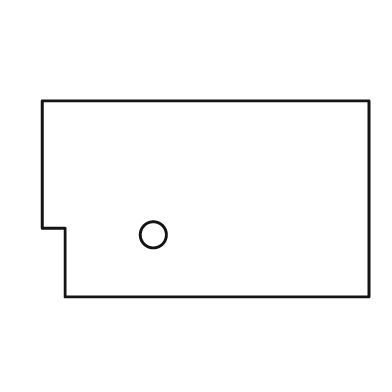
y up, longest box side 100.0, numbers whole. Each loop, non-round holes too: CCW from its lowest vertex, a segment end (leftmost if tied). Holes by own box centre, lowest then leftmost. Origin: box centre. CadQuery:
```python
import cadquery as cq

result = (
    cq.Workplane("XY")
    .moveTo(-43.0, -30.0)
    .lineTo(50.0, -30.0)
    .lineTo(50.0, 30.0)
    .lineTo(-50.0, 30.0)
    .lineTo(-50.0, -9.0)
    .lineTo(-43.0, -9.0)
    .close()
    .moveTo(-16.0, -11.0)
    .circle(4.0)
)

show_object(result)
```